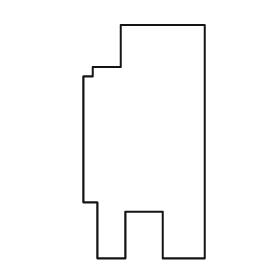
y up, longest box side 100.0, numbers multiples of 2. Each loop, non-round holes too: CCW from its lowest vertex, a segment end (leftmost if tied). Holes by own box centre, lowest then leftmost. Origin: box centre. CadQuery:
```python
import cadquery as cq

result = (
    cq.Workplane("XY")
    .moveTo(-20.0, -50.0)
    .lineTo(-8.0, -50.0)
    .lineTo(-8.0, -30.0)
    .lineTo(8.0, -30.0)
    .lineTo(8.0, -50.0)
    .lineTo(26.0, -50.0)
    .lineTo(26.0, 50.0)
    .lineTo(-10.0, 50.0)
    .lineTo(-10.0, 32.0)
    .lineTo(-22.0, 32.0)
    .lineTo(-22.0, 28.0)
    .lineTo(-26.0, 28.0)
    .lineTo(-26.0, -26.0)
    .lineTo(-20.0, -26.0)
    .close()
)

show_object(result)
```